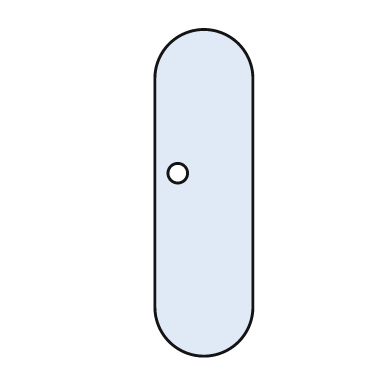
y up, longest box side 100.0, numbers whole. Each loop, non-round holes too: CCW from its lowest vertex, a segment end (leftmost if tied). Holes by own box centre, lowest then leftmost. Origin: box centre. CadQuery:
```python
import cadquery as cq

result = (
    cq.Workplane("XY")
    .moveTo(-15.0, -35.0)
    .threePointArc((0.0, -50.0), (15.0, -35.0))
    .lineTo(15.0, 35.0)
    .threePointArc((0.0, 50.0), (-15.0, 35.0))
    .close()
    .moveTo(-8.0, 6.0)
    .circle(3.0)
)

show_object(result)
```